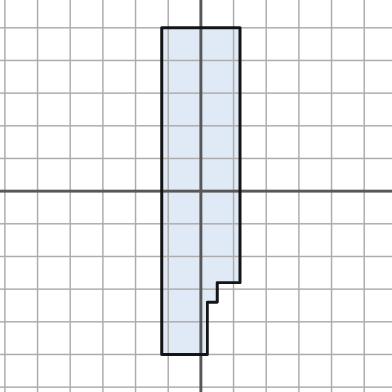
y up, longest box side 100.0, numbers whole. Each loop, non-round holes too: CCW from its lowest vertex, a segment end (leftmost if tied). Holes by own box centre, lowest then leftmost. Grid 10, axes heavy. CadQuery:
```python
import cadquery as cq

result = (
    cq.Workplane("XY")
    .moveTo(-12.0, -50.0)
    .lineTo(2.0, -50.0)
    .lineTo(2.0, -34.0)
    .lineTo(5.0, -34.0)
    .lineTo(5.0, -28.0)
    .lineTo(12.0, -28.0)
    .lineTo(12.0, 50.0)
    .lineTo(-12.0, 50.0)
    .close()
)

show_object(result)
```